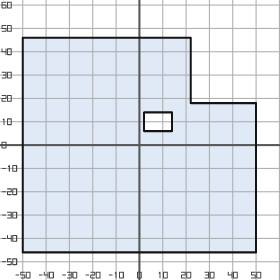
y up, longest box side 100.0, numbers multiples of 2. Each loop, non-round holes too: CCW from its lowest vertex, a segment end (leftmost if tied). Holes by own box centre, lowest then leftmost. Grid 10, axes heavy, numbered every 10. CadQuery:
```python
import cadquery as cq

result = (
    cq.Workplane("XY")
    .moveTo(-50.0, -46.0)
    .lineTo(50.0, -46.0)
    .lineTo(50.0, 18.0)
    .lineTo(22.0, 18.0)
    .lineTo(22.0, 46.0)
    .lineTo(-50.0, 46.0)
    .close()
    .moveTo(2.0, 6.0)
    .lineTo(14.0, 6.0)
    .lineTo(14.0, 14.0)
    .lineTo(2.0, 14.0)
    .close()
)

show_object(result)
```